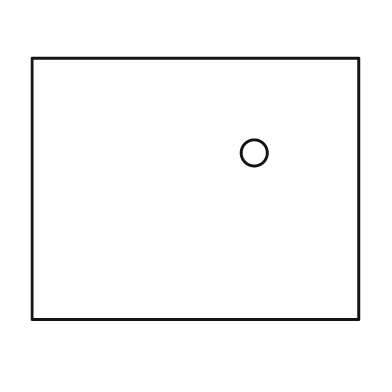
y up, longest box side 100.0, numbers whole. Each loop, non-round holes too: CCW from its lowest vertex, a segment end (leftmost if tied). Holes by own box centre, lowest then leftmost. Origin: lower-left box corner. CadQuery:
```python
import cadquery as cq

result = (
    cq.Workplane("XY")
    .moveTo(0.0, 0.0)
    .lineTo(100.0, 0.0)
    .lineTo(100.0, 80.0)
    .lineTo(0.0, 80.0)
    .close()
    .moveTo(68.0, 51.0)
    .circle(4.0)
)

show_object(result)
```